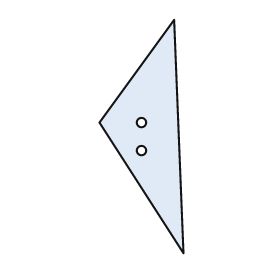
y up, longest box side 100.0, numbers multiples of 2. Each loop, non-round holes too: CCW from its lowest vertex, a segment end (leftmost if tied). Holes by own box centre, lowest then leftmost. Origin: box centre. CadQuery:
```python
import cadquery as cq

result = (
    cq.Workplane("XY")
    .moveTo(18.0, -50.0)
    .lineTo(14.0, 50.0)
    .lineTo(-18.0, 6.0)
    .close()
    .moveTo(0.0, -6.0)
    .circle(2.0)
    .moveTo(0.0, 6.0)
    .circle(2.0)
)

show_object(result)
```